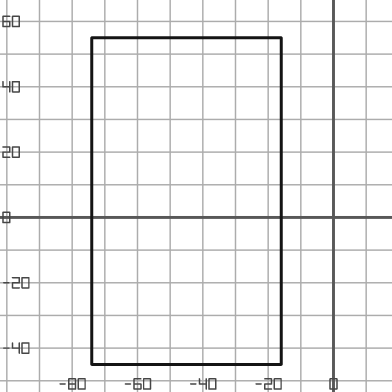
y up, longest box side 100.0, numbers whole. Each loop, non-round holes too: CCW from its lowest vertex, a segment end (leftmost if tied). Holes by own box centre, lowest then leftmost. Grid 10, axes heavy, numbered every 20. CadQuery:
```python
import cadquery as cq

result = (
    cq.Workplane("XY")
    .moveTo(-74.0, -45.0)
    .lineTo(-16.0, -45.0)
    .lineTo(-16.0, 55.0)
    .lineTo(-74.0, 55.0)
    .close()
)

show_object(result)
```